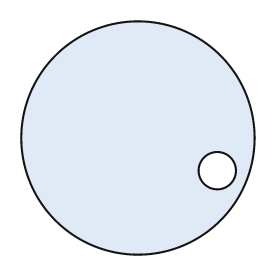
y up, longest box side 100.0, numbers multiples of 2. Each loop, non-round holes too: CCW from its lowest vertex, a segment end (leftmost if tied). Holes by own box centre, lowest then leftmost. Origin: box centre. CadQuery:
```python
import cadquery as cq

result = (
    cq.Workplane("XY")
    .moveTo(0.0, 0.0)
    .circle(50.0)
    .moveTo(34.0, -14.0)
    .circle(8.0)
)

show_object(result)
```